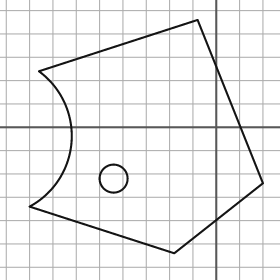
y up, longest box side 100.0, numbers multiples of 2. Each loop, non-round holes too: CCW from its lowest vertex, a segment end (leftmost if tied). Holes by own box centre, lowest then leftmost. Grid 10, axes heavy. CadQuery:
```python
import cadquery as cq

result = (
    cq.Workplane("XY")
    .moveTo(-18.0, -54.0)
    .lineTo(20.0, -24.0)
    .lineTo(-8.0, 46.0)
    .lineTo(-76.0, 24.0)
    .threePointArc((-62.0, -6.0), (-80.0, -34.0))
    .close()
    .moveTo(-44.0, -22.0)
    .circle(6.0)
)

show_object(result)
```